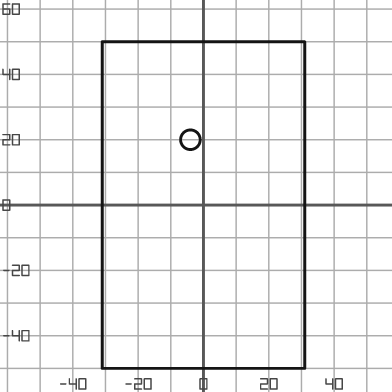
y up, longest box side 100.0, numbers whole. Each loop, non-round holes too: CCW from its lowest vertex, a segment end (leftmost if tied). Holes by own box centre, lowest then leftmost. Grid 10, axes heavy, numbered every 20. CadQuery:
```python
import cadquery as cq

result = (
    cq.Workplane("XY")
    .moveTo(-31.0, -50.0)
    .lineTo(31.0, -50.0)
    .lineTo(31.0, 50.0)
    .lineTo(-31.0, 50.0)
    .close()
    .moveTo(-4.0, 20.0)
    .circle(3.0)
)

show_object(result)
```